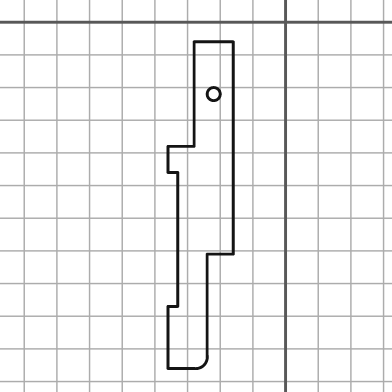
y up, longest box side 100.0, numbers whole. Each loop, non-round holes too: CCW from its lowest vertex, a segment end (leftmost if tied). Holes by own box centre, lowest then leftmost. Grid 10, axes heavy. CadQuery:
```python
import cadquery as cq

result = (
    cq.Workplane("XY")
    .moveTo(-36.0, -106.0)
    .lineTo(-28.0, -106.0)
    .threePointArc((-25.0, -105.0), (-24.0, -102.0))
    .lineTo(-24.0, -71.0)
    .lineTo(-16.0, -71.0)
    .lineTo(-16.0, -6.0)
    .lineTo(-28.0, -6.0)
    .lineTo(-28.0, -38.0)
    .lineTo(-36.0, -38.0)
    .lineTo(-36.0, -46.0)
    .lineTo(-33.0, -46.0)
    .lineTo(-33.0, -87.0)
    .lineTo(-36.0, -87.0)
    .close()
    .moveTo(-22.0, -22.0)
    .circle(2.0)
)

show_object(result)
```